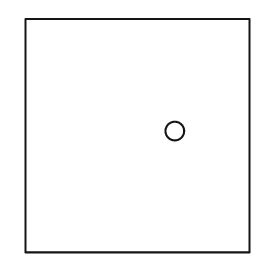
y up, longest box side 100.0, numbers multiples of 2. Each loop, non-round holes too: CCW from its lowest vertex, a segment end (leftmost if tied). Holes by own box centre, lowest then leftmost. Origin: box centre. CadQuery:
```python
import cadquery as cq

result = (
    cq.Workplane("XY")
    .moveTo(-48.0, -50.0)
    .lineTo(48.0, -50.0)
    .lineTo(48.0, 50.0)
    .lineTo(-48.0, 50.0)
    .close()
    .moveTo(16.0, 2.0)
    .circle(4.0)
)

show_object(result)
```